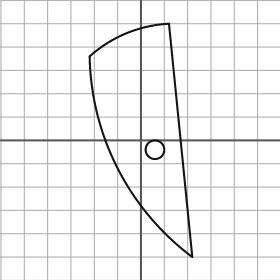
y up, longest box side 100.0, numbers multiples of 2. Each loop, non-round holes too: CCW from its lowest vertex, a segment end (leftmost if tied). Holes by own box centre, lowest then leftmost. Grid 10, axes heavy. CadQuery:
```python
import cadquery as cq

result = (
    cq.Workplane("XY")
    .moveTo(22.0, -50.0)
    .lineTo(12.0, 50.0)
    .threePointArc((-6.0, 46.0), (-22.0, 36.0))
    .threePointArc((-10.0, -12.0), (22.0, -50.0))
    .close()
    .moveTo(6.0, -4.0)
    .circle(4.0)
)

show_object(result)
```